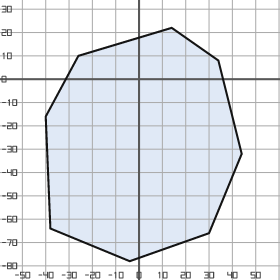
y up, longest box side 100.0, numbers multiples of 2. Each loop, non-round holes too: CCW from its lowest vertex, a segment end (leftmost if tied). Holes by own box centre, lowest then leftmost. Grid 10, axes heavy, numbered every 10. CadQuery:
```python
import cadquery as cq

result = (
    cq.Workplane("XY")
    .moveTo(-4.0, -78.0)
    .lineTo(30.0, -66.0)
    .lineTo(44.0, -32.0)
    .lineTo(34.0, 8.0)
    .lineTo(14.0, 22.0)
    .lineTo(-26.0, 10.0)
    .lineTo(-40.0, -16.0)
    .lineTo(-38.0, -64.0)
    .close()
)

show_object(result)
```